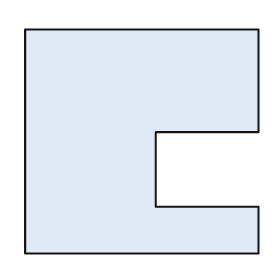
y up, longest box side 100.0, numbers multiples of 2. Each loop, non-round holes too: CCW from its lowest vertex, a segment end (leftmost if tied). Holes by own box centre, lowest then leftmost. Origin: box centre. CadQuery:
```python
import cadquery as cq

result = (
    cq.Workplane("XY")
    .moveTo(-50.0, -48.0)
    .lineTo(50.0, -48.0)
    .lineTo(50.0, -28.0)
    .lineTo(6.0, -28.0)
    .lineTo(6.0, 4.0)
    .lineTo(50.0, 4.0)
    .lineTo(50.0, 48.0)
    .lineTo(-50.0, 48.0)
    .close()
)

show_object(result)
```